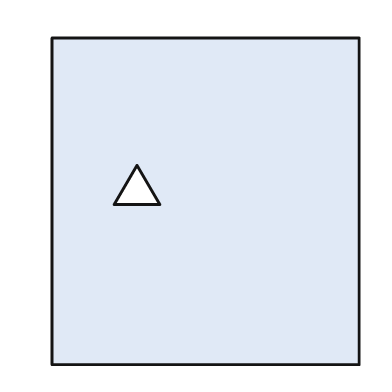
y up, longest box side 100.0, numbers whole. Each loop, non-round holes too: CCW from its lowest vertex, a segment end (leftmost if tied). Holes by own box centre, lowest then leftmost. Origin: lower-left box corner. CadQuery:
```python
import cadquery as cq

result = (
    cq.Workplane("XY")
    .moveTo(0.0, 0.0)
    .lineTo(94.0, 0.0)
    .lineTo(94.0, 100.0)
    .lineTo(0.0, 100.0)
    .close()
    .moveTo(19.0, 49.0)
    .lineTo(33.0, 49.0)
    .lineTo(26.0, 61.0)
    .close()
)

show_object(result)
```